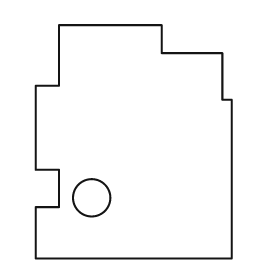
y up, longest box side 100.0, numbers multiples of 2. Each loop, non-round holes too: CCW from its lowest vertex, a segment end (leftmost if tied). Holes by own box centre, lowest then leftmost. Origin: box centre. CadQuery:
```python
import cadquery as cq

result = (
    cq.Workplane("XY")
    .moveTo(-42.0, -50.0)
    .lineTo(42.0, -50.0)
    .lineTo(42.0, 18.0)
    .lineTo(38.0, 18.0)
    .lineTo(38.0, 38.0)
    .lineTo(12.0, 38.0)
    .lineTo(12.0, 50.0)
    .lineTo(-32.0, 50.0)
    .lineTo(-32.0, 24.0)
    .lineTo(-42.0, 24.0)
    .lineTo(-42.0, -12.0)
    .lineTo(-32.0, -12.0)
    .lineTo(-32.0, -28.0)
    .lineTo(-42.0, -28.0)
    .close()
    .moveTo(-18.0, -24.0)
    .circle(8.0)
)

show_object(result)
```